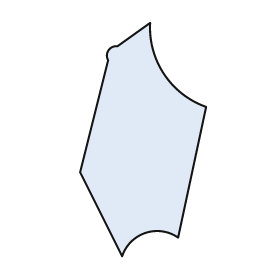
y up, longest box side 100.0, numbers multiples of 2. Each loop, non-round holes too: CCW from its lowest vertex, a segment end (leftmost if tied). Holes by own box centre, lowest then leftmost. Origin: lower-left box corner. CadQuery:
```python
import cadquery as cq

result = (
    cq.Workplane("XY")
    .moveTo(18.0, 0.0)
    .threePointArc((28.0, 10.0), (42.0, 8.0))
    .lineTo(54.0, 64.0)
    .threePointArc((36.0, 78.0), (30.0, 100.0))
    .lineTo(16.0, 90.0)
    .threePointArc((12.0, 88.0), (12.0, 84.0))
    .lineTo(0.0, 36.0)
    .close()
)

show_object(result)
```